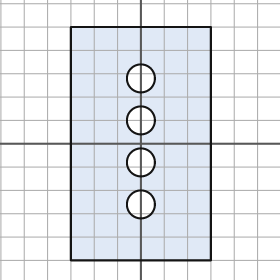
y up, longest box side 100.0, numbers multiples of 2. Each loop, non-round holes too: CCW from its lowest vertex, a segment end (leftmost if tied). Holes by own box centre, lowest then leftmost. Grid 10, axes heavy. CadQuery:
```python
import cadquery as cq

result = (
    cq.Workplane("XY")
    .moveTo(-30.0, -50.0)
    .lineTo(30.0, -50.0)
    .lineTo(30.0, 50.0)
    .lineTo(-30.0, 50.0)
    .close()
    .moveTo(0.0, -26.0)
    .circle(6.0)
    .moveTo(0.0, -8.0)
    .circle(6.0)
    .moveTo(0.0, 10.0)
    .circle(6.0)
    .moveTo(0.0, 28.0)
    .circle(6.0)
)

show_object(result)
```